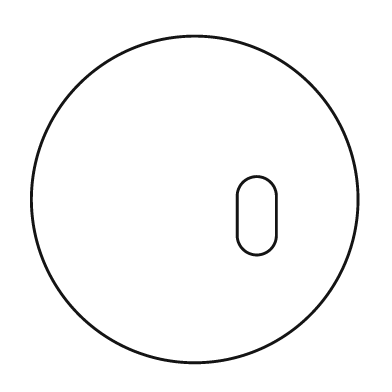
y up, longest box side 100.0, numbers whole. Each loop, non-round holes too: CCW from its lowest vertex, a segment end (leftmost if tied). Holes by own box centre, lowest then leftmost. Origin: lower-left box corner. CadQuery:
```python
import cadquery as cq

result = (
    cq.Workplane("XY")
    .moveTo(50.0, 50.0)
    .circle(50.0)
    .moveTo(63.0, 39.0)
    .threePointArc((69.0, 33.0), (75.0, 39.0))
    .lineTo(75.0, 51.0)
    .threePointArc((69.0, 57.0), (63.0, 51.0))
    .close()
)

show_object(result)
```